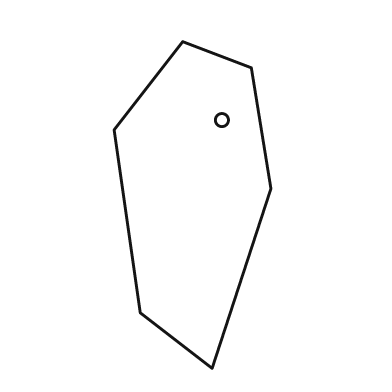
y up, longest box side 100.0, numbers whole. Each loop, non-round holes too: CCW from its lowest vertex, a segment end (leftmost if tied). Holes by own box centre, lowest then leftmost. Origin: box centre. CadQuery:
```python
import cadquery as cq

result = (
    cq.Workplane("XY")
    .moveTo(6.0, -50.0)
    .lineTo(24.0, 5.0)
    .lineTo(18.0, 42.0)
    .lineTo(-3.0, 50.0)
    .lineTo(-24.0, 23.0)
    .lineTo(-16.0, -33.0)
    .close()
    .moveTo(9.0, 26.0)
    .circle(2.0)
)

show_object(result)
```